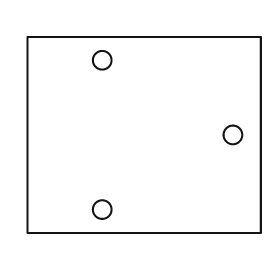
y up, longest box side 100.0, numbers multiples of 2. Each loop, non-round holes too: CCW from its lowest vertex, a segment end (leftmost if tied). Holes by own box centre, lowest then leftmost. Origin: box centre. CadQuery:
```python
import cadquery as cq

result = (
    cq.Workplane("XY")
    .moveTo(-50.0, -42.0)
    .lineTo(50.0, -42.0)
    .lineTo(50.0, 42.0)
    .lineTo(-50.0, 42.0)
    .close()
    .moveTo(-18.0, -32.0)
    .circle(4.0)
    .moveTo(38.0, 0.0)
    .circle(4.0)
    .moveTo(-18.0, 32.0)
    .circle(4.0)
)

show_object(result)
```